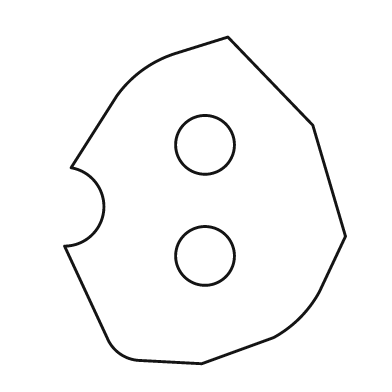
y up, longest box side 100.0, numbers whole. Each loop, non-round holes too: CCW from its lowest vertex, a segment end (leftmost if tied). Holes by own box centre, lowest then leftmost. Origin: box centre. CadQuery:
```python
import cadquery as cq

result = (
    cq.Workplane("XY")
    .moveTo(-1.0, -50.0)
    .lineTo(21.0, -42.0)
    .threePointArc((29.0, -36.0), (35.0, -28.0))
    .lineTo(43.0, -11.0)
    .lineTo(33.0, 23.0)
    .lineTo(7.0, 50.0)
    .lineTo(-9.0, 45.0)
    .threePointArc((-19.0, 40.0), (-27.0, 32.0))
    .lineTo(-41.0, 10.0)
    .threePointArc((-31.0, -3.0), (-43.0, -14.0))
    .lineTo(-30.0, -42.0)
    .threePointArc((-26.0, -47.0), (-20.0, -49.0))
    .close()
    .moveTo(0.0, -17.0)
    .circle(9.0)
    .moveTo(0.0, 17.0)
    .circle(9.0)
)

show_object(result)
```